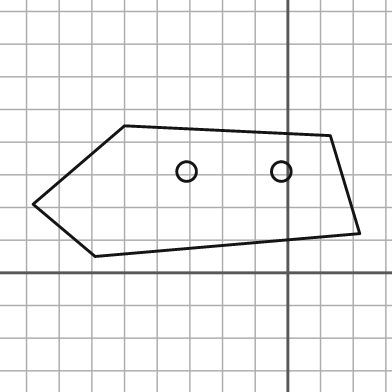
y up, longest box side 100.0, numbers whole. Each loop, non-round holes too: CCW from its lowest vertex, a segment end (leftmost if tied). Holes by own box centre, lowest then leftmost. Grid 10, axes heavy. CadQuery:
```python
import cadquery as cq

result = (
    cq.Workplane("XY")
    .moveTo(-59.0, 5.0)
    .lineTo(22.0, 12.0)
    .lineTo(13.0, 42.0)
    .lineTo(-50.0, 45.0)
    .lineTo(-78.0, 21.0)
    .close()
    .moveTo(-31.0, 31.0)
    .circle(3.0)
    .moveTo(-2.0, 31.0)
    .circle(3.0)
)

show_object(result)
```